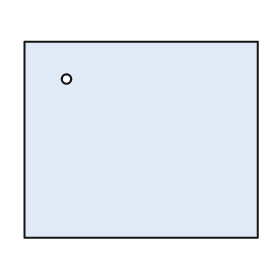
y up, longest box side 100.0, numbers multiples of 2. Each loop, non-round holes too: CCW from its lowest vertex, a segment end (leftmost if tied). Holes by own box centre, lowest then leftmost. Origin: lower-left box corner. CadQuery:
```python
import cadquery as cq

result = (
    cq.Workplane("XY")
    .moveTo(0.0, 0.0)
    .lineTo(100.0, 0.0)
    .lineTo(100.0, 84.0)
    .lineTo(0.0, 84.0)
    .close()
    .moveTo(18.0, 68.0)
    .circle(2.0)
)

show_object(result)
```